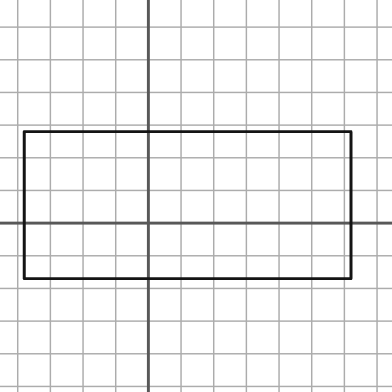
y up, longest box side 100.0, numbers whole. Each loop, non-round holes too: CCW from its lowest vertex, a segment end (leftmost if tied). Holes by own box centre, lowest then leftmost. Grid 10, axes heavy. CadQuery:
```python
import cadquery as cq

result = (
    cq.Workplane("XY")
    .moveTo(-38.0, -17.0)
    .lineTo(62.0, -17.0)
    .lineTo(62.0, 28.0)
    .lineTo(-38.0, 28.0)
    .close()
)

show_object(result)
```